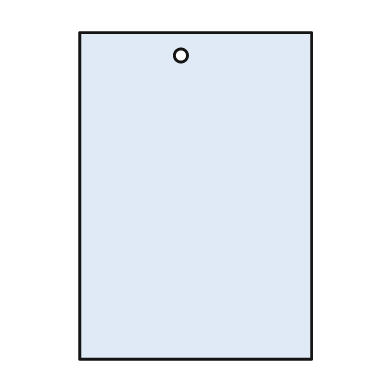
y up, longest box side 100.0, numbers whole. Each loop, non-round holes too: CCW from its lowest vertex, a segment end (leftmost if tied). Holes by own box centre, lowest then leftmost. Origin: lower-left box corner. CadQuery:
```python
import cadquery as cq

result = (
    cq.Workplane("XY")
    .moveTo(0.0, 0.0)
    .lineTo(71.0, 0.0)
    .lineTo(71.0, 100.0)
    .lineTo(0.0, 100.0)
    .close()
    .moveTo(31.0, 93.0)
    .circle(2.0)
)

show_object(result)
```